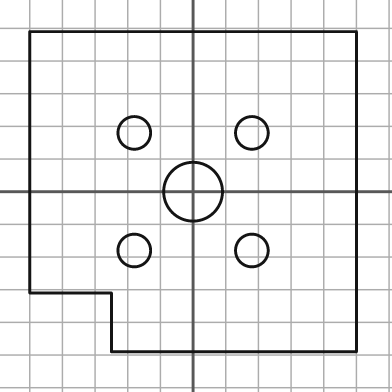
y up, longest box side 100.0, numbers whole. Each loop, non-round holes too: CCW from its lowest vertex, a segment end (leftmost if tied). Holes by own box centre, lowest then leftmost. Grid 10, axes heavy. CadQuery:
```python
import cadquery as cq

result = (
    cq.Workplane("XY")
    .moveTo(-25.0, -49.0)
    .lineTo(50.0, -49.0)
    .lineTo(50.0, 49.0)
    .lineTo(-50.0, 49.0)
    .lineTo(-50.0, -31.0)
    .lineTo(-25.0, -31.0)
    .close()
    .moveTo(-18.0, -18.0)
    .circle(5.0)
    .moveTo(18.0, -18.0)
    .circle(5.0)
    .moveTo(0.0, 0.0)
    .circle(9.0)
    .moveTo(-18.0, 18.0)
    .circle(5.0)
    .moveTo(18.0, 18.0)
    .circle(5.0)
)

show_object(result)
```